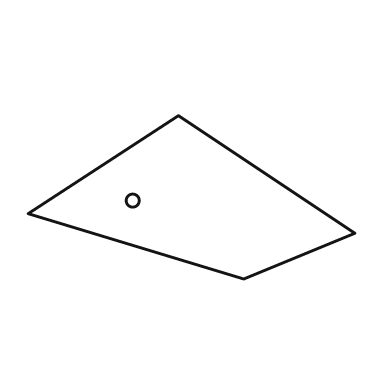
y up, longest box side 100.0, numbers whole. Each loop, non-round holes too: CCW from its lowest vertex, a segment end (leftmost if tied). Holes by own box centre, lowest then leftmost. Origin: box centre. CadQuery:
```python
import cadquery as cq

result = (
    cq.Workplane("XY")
    .moveTo(16.0, -25.0)
    .lineTo(50.0, -11.0)
    .lineTo(-4.0, 25.0)
    .lineTo(-50.0, -5.0)
    .close()
    .moveTo(-18.0, -1.0)
    .circle(2.0)
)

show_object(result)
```